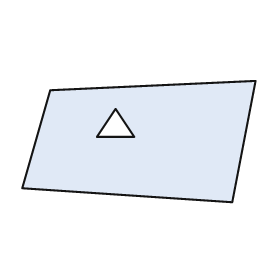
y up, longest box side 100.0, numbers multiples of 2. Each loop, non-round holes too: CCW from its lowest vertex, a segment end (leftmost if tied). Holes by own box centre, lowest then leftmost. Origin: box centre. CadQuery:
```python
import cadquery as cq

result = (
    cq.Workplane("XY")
    .moveTo(40.0, -26.0)
    .lineTo(50.0, 26.0)
    .lineTo(-38.0, 22.0)
    .lineTo(-50.0, -20.0)
    .close()
    .moveTo(-18.0, 2.0)
    .lineTo(-2.0, 2.0)
    .lineTo(-10.0, 14.0)
    .close()
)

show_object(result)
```